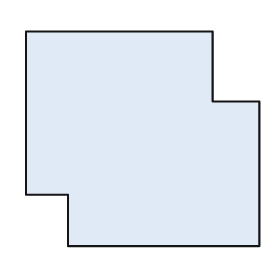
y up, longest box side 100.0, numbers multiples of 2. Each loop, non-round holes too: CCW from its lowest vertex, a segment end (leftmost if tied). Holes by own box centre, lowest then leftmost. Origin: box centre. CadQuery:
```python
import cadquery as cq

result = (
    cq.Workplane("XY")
    .moveTo(-32.0, -46.0)
    .lineTo(50.0, -46.0)
    .lineTo(50.0, 16.0)
    .lineTo(30.0, 16.0)
    .lineTo(30.0, 46.0)
    .lineTo(-50.0, 46.0)
    .lineTo(-50.0, -24.0)
    .lineTo(-32.0, -24.0)
    .close()
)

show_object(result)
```